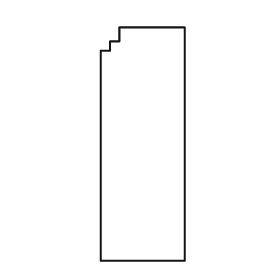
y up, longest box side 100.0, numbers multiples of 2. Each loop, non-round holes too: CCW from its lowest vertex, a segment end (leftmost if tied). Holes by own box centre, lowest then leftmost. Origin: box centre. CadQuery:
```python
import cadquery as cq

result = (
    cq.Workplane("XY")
    .moveTo(-18.0, -50.0)
    .lineTo(18.0, -50.0)
    .lineTo(18.0, 50.0)
    .lineTo(-10.0, 50.0)
    .lineTo(-10.0, 44.0)
    .lineTo(-14.0, 44.0)
    .lineTo(-14.0, 40.0)
    .lineTo(-18.0, 40.0)
    .close()
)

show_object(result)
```